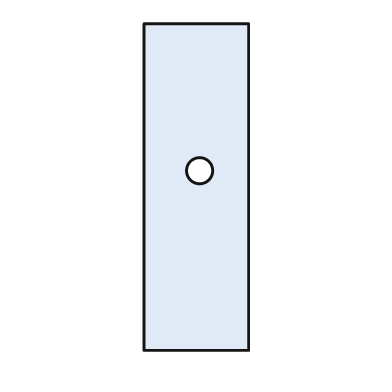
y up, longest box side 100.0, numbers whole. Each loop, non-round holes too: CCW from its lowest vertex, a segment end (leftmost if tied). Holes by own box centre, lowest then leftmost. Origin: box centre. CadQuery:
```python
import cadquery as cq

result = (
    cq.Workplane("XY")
    .moveTo(-16.0, -50.0)
    .lineTo(16.0, -50.0)
    .lineTo(16.0, 50.0)
    .lineTo(-16.0, 50.0)
    .close()
    .moveTo(1.0, 5.0)
    .circle(4.0)
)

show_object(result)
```